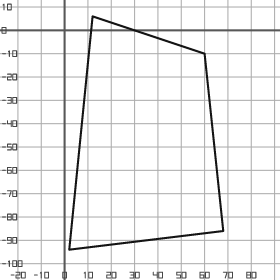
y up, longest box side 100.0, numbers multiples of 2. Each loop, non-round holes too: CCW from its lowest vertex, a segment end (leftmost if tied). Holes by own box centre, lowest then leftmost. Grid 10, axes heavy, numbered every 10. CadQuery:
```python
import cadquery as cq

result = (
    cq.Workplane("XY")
    .moveTo(2.0, -94.0)
    .lineTo(68.0, -86.0)
    .lineTo(60.0, -10.0)
    .lineTo(12.0, 6.0)
    .close()
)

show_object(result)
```